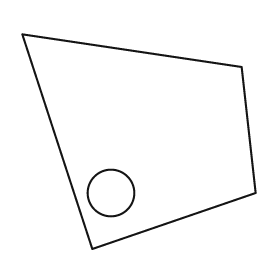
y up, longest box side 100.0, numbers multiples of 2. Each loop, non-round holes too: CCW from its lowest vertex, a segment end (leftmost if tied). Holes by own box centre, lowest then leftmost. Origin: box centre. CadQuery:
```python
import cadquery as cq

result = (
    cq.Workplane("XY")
    .moveTo(-20.0, -46.0)
    .lineTo(50.0, -22.0)
    .lineTo(44.0, 32.0)
    .lineTo(-50.0, 46.0)
    .close()
    .moveTo(-12.0, -22.0)
    .circle(10.0)
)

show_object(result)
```